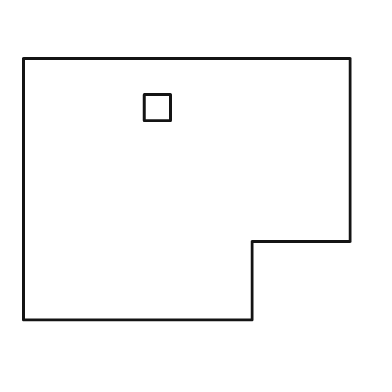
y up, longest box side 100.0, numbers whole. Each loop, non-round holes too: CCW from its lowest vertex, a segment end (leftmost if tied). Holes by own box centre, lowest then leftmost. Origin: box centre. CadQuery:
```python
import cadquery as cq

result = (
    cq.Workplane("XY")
    .moveTo(-50.0, -40.0)
    .lineTo(20.0, -40.0)
    .lineTo(20.0, -16.0)
    .lineTo(50.0, -16.0)
    .lineTo(50.0, 40.0)
    .lineTo(-50.0, 40.0)
    .close()
    .moveTo(-13.0, 21.0)
    .lineTo(-5.0, 21.0)
    .lineTo(-5.0, 29.0)
    .lineTo(-13.0, 29.0)
    .close()
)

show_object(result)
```